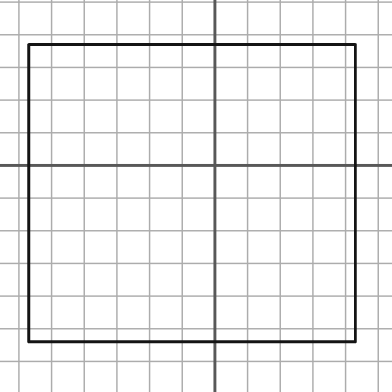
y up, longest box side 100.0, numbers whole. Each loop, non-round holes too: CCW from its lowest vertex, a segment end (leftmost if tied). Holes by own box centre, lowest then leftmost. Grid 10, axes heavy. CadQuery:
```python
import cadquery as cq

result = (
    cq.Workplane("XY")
    .moveTo(-57.0, -54.0)
    .lineTo(43.0, -54.0)
    .lineTo(43.0, 37.0)
    .lineTo(-57.0, 37.0)
    .close()
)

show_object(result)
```